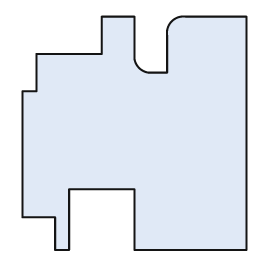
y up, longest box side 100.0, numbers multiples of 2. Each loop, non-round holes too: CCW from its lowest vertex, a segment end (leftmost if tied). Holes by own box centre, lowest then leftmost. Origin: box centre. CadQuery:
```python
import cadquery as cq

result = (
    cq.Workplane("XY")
    .moveTo(-34.0, -50.0)
    .lineTo(-28.0, -50.0)
    .lineTo(-28.0, -24.0)
    .lineTo(0.0, -24.0)
    .lineTo(0.0, -50.0)
    .lineTo(48.0, -50.0)
    .lineTo(48.0, 50.0)
    .lineTo(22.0, 50.0)
    .threePointArc((16.0, 48.0), (14.0, 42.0))
    .lineTo(14.0, 26.0)
    .lineTo(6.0, 26.0)
    .threePointArc((2.0, 28.0), (0.0, 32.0))
    .lineTo(0.0, 50.0)
    .lineTo(-14.0, 50.0)
    .lineTo(-14.0, 34.0)
    .lineTo(-42.0, 34.0)
    .lineTo(-42.0, 18.0)
    .lineTo(-48.0, 18.0)
    .lineTo(-48.0, -36.0)
    .lineTo(-34.0, -36.0)
    .close()
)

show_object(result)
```